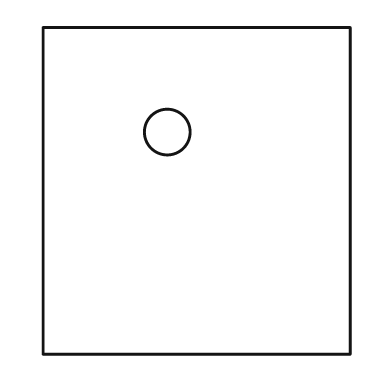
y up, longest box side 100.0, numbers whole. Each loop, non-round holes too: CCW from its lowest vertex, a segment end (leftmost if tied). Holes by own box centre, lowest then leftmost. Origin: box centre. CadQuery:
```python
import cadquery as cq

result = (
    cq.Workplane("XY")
    .moveTo(-47.0, -50.0)
    .lineTo(47.0, -50.0)
    .lineTo(47.0, 50.0)
    .lineTo(-47.0, 50.0)
    .close()
    .moveTo(-9.0, 18.0)
    .circle(7.0)
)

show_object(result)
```